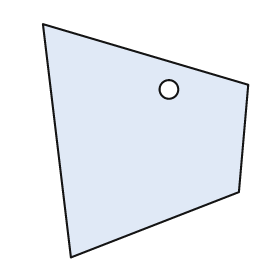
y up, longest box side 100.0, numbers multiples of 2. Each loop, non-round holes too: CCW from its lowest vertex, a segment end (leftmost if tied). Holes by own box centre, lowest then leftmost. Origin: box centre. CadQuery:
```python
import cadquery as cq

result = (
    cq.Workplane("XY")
    .moveTo(-32.0, -50.0)
    .lineTo(40.0, -22.0)
    .lineTo(44.0, 24.0)
    .lineTo(-44.0, 50.0)
    .close()
    .moveTo(10.0, 22.0)
    .circle(4.0)
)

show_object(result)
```